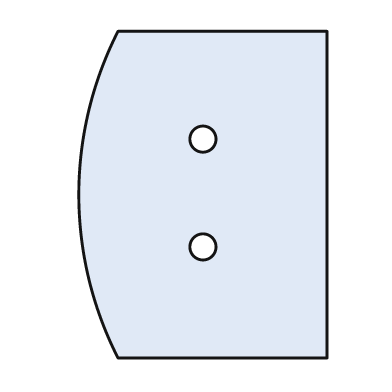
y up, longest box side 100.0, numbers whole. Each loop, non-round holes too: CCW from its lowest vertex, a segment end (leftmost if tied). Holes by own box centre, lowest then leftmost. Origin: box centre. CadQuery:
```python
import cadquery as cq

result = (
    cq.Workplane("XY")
    .moveTo(-26.0, -50.0)
    .lineTo(38.0, -50.0)
    .lineTo(38.0, 50.0)
    .lineTo(-26.0, 50.0)
    .threePointArc((-38.0, 0.0), (-26.0, -50.0))
    .close()
    .moveTo(0.0, -16.0)
    .circle(4.0)
    .moveTo(0.0, 17.0)
    .circle(4.0)
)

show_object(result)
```